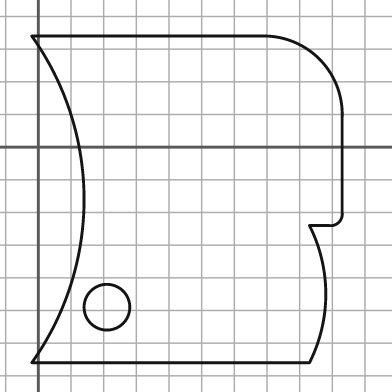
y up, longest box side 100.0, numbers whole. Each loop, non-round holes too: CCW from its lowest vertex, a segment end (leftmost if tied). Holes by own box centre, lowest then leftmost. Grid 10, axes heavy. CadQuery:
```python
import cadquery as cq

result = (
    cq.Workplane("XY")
    .moveTo(-2.0, -66.0)
    .lineTo(83.0, -66.0)
    .threePointArc((88.0, -45.0), (83.0, -24.0))
    .lineTo(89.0, -24.0)
    .threePointArc((92.0, -23.0), (93.0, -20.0))
    .lineTo(93.0, 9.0)
    .threePointArc((86.0, 27.0), (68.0, 34.0))
    .lineTo(-2.0, 34.0)
    .threePointArc((14.0, -16.0), (-2.0, -66.0))
    .close()
    .moveTo(21.0, -49.0)
    .circle(7.0)
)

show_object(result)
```